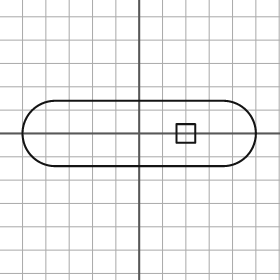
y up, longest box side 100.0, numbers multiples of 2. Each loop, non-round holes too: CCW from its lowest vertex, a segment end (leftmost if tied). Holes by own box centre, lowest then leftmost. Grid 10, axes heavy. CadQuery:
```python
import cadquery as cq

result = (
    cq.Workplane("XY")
    .moveTo(-36.0, -14.0)
    .lineTo(36.0, -14.0)
    .threePointArc((50.0, 0.0), (36.0, 14.0))
    .lineTo(-36.0, 14.0)
    .threePointArc((-50.0, 0.0), (-36.0, -14.0))
    .close()
    .moveTo(16.0, -4.0)
    .lineTo(24.0, -4.0)
    .lineTo(24.0, 4.0)
    .lineTo(16.0, 4.0)
    .close()
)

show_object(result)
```